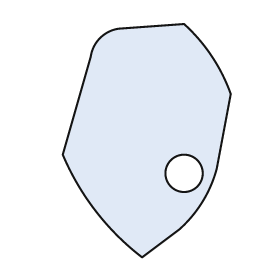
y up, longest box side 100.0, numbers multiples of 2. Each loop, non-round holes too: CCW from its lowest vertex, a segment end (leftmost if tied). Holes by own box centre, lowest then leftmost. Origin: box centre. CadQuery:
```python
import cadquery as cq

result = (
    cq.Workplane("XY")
    .moveTo(-2.0, -50.0)
    .lineTo(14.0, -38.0)
    .threePointArc((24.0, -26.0), (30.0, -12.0))
    .lineTo(36.0, 20.0)
    .threePointArc((28.0, 36.0), (16.0, 50.0))
    .lineTo(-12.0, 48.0)
    .threePointArc((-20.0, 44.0), (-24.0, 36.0))
    .lineTo(-36.0, -6.0)
    .threePointArc((-22.0, -30.0), (-2.0, -50.0))
    .close()
    .moveTo(16.0, -14.0)
    .circle(8.0)
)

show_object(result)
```